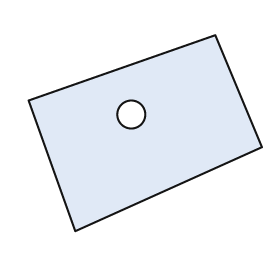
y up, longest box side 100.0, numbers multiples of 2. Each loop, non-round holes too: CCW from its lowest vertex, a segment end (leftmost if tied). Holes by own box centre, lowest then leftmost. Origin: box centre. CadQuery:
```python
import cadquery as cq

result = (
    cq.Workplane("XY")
    .moveTo(-30.0, -42.0)
    .lineTo(50.0, -6.0)
    .lineTo(30.0, 42.0)
    .lineTo(-50.0, 14.0)
    .close()
    .moveTo(-6.0, 8.0)
    .circle(6.0)
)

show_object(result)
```